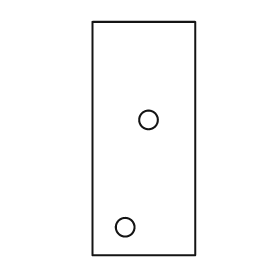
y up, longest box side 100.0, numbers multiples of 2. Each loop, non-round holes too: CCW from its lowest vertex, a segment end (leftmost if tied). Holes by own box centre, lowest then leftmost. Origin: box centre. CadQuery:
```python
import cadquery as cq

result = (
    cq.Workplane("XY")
    .moveTo(-22.0, -50.0)
    .lineTo(22.0, -50.0)
    .lineTo(22.0, 50.0)
    .lineTo(-22.0, 50.0)
    .close()
    .moveTo(-8.0, -38.0)
    .circle(4.0)
    .moveTo(2.0, 8.0)
    .circle(4.0)
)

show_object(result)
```